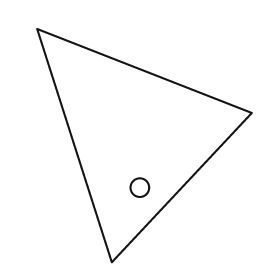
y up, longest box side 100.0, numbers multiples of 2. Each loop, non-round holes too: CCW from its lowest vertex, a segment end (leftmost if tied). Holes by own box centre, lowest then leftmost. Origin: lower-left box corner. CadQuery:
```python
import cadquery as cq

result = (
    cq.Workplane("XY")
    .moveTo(32.0, 0.0)
    .lineTo(92.0, 64.0)
    .lineTo(0.0, 100.0)
    .close()
    .moveTo(44.0, 32.0)
    .circle(4.0)
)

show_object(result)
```